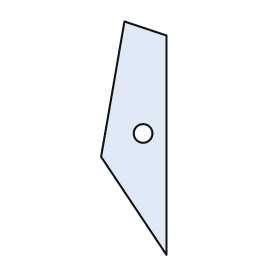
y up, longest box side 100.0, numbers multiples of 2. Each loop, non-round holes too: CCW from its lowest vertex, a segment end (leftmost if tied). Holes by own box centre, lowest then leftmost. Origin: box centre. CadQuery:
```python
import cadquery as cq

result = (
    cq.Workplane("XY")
    .moveTo(14.0, -50.0)
    .lineTo(14.0, 44.0)
    .lineTo(-4.0, 50.0)
    .lineTo(-14.0, -8.0)
    .close()
    .moveTo(4.0, 2.0)
    .circle(4.0)
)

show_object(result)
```